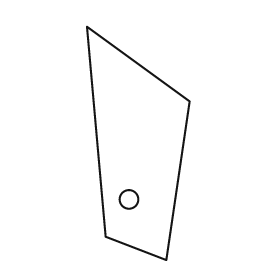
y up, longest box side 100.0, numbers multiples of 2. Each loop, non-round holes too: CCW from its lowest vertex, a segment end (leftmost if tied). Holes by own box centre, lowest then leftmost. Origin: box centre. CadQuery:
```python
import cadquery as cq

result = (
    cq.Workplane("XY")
    .moveTo(12.0, -50.0)
    .lineTo(22.0, 18.0)
    .lineTo(-22.0, 50.0)
    .lineTo(-14.0, -40.0)
    .close()
    .moveTo(-4.0, -24.0)
    .circle(4.0)
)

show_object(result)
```